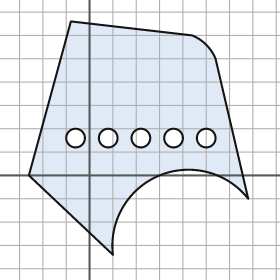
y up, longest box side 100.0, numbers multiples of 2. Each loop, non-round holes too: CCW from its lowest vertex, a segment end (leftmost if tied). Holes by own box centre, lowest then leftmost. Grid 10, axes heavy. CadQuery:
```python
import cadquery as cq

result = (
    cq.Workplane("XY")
    .moveTo(10.0, -34.0)
    .threePointArc((30.0, 0.0), (68.0, -10.0))
    .lineTo(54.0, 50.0)
    .threePointArc((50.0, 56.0), (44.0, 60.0))
    .lineTo(-8.0, 66.0)
    .lineTo(-26.0, 0.0)
    .close()
    .moveTo(-6.0, 16.0)
    .circle(4.0)
    .moveTo(8.0, 16.0)
    .circle(4.0)
    .moveTo(22.0, 16.0)
    .circle(4.0)
    .moveTo(36.0, 16.0)
    .circle(4.0)
    .moveTo(50.0, 16.0)
    .circle(4.0)
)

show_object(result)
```